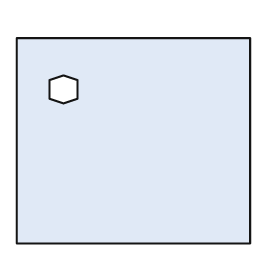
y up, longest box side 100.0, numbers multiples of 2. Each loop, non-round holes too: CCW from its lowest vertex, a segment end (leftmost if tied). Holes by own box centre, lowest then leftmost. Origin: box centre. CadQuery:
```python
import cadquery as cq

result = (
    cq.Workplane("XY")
    .moveTo(-50.0, -44.0)
    .lineTo(50.0, -44.0)
    .lineTo(50.0, 44.0)
    .lineTo(-50.0, 44.0)
    .close()
    .moveTo(-30.0, 16.0)
    .lineTo(-24.0, 18.0)
    .lineTo(-24.0, 26.0)
    .lineTo(-30.0, 28.0)
    .lineTo(-36.0, 26.0)
    .lineTo(-36.0, 18.0)
    .close()
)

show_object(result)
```